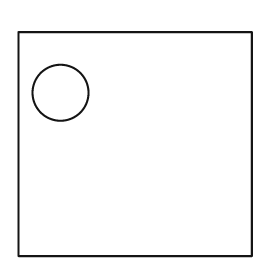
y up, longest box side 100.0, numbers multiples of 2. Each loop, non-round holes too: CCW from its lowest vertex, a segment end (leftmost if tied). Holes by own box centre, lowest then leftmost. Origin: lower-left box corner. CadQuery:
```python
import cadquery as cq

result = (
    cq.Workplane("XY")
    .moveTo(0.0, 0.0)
    .lineTo(100.0, 0.0)
    .lineTo(100.0, 96.0)
    .lineTo(0.0, 96.0)
    .close()
    .moveTo(18.0, 70.0)
    .circle(12.0)
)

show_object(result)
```